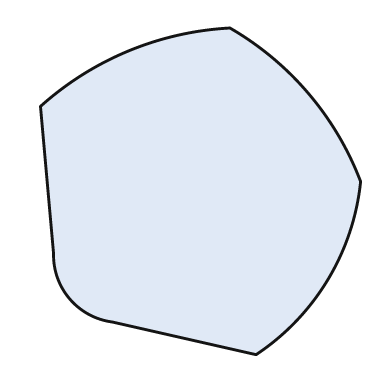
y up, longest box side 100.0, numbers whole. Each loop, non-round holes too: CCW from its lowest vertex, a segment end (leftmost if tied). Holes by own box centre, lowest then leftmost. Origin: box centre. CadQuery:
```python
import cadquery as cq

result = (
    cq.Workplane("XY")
    .moveTo(17.0, -50.0)
    .threePointArc((39.0, -27.0), (49.0, 3.0))
    .threePointArc((33.0, 30.0), (9.0, 50.0))
    .threePointArc((-22.0, 43.0), (-49.0, 26.0))
    .lineTo(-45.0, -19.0)
    .threePointArc((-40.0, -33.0), (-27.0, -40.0))
    .close()
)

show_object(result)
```